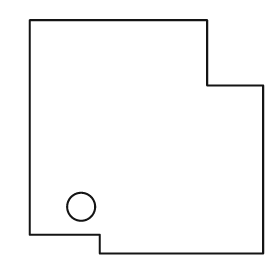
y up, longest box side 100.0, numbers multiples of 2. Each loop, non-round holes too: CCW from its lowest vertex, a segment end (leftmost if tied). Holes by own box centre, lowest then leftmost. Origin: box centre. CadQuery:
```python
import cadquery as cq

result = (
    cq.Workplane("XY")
    .moveTo(-20.0, -50.0)
    .lineTo(50.0, -50.0)
    .lineTo(50.0, 22.0)
    .lineTo(26.0, 22.0)
    .lineTo(26.0, 50.0)
    .lineTo(-50.0, 50.0)
    .lineTo(-50.0, -42.0)
    .lineTo(-20.0, -42.0)
    .close()
    .moveTo(-28.0, -30.0)
    .circle(6.0)
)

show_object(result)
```